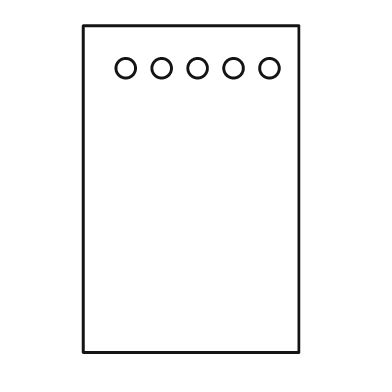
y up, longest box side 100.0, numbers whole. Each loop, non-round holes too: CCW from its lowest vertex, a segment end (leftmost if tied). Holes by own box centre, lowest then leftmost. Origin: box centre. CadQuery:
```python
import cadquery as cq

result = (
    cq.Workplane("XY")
    .moveTo(-33.0, -50.0)
    .lineTo(33.0, -50.0)
    .lineTo(33.0, 50.0)
    .lineTo(-33.0, 50.0)
    .close()
    .moveTo(-20.0, 37.0)
    .circle(3.0)
    .moveTo(-9.0, 37.0)
    .circle(3.0)
    .moveTo(2.0, 37.0)
    .circle(3.0)
    .moveTo(13.0, 37.0)
    .circle(3.0)
    .moveTo(24.0, 37.0)
    .circle(3.0)
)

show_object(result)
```